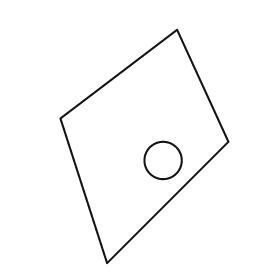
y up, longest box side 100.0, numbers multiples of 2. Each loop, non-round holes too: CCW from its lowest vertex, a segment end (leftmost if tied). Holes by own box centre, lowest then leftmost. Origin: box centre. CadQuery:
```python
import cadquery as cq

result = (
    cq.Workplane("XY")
    .moveTo(-16.0, -50.0)
    .lineTo(36.0, 2.0)
    .lineTo(14.0, 50.0)
    .lineTo(-36.0, 12.0)
    .close()
    .moveTo(8.0, -6.0)
    .circle(8.0)
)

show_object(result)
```